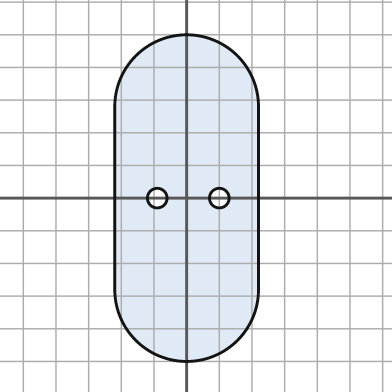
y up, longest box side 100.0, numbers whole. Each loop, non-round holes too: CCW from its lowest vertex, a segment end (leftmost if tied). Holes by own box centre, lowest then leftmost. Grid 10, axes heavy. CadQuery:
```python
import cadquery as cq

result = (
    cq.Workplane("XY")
    .moveTo(-22.0, -28.0)
    .threePointArc((0.0, -50.0), (22.0, -28.0))
    .lineTo(22.0, 28.0)
    .threePointArc((0.0, 50.0), (-22.0, 28.0))
    .close()
    .moveTo(-9.0, 0.0)
    .circle(3.0)
    .moveTo(10.0, 0.0)
    .circle(3.0)
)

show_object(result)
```